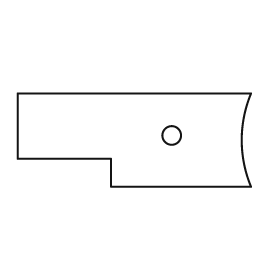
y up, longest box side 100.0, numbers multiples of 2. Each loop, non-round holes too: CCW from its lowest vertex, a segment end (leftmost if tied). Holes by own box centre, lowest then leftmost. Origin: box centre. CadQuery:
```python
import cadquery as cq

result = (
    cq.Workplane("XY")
    .moveTo(-10.0, -20.0)
    .lineTo(50.0, -20.0)
    .threePointArc((46.0, 0.0), (50.0, 20.0))
    .lineTo(-50.0, 20.0)
    .lineTo(-50.0, -8.0)
    .lineTo(-10.0, -8.0)
    .close()
    .moveTo(16.0, 2.0)
    .circle(4.0)
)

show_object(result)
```